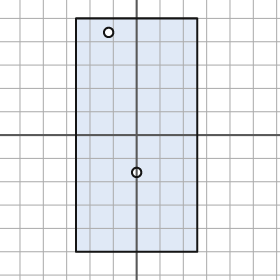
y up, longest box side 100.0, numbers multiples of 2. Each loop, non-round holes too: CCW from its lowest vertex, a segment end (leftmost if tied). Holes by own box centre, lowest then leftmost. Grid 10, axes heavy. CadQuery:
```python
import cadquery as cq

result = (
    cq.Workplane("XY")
    .moveTo(-26.0, -50.0)
    .lineTo(26.0, -50.0)
    .lineTo(26.0, 50.0)
    .lineTo(-26.0, 50.0)
    .close()
    .moveTo(0.0, -16.0)
    .circle(2.0)
    .moveTo(-12.0, 44.0)
    .circle(2.0)
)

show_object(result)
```